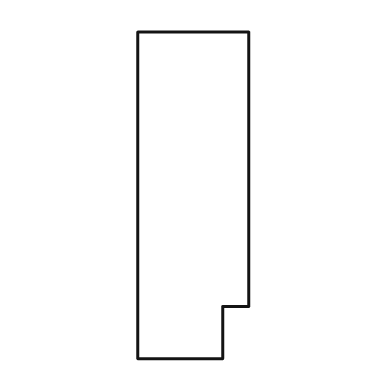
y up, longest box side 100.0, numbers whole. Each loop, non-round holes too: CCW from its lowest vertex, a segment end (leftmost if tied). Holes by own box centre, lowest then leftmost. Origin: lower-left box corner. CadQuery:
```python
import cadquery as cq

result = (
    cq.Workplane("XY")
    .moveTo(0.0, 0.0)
    .lineTo(26.0, 0.0)
    .lineTo(26.0, 16.0)
    .lineTo(34.0, 16.0)
    .lineTo(34.0, 100.0)
    .lineTo(0.0, 100.0)
    .close()
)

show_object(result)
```